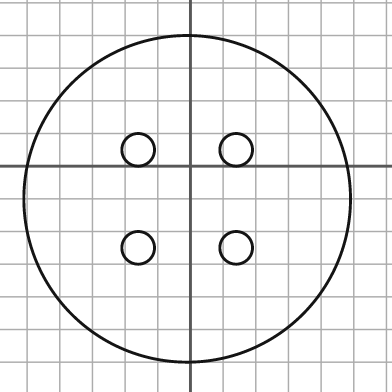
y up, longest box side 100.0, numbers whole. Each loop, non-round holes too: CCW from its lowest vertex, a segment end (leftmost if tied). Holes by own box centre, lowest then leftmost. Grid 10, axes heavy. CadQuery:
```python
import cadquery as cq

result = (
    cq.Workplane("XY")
    .moveTo(-1.0, -10.0)
    .circle(50.0)
    .moveTo(-16.0, -25.0)
    .circle(5.0)
    .moveTo(14.0, -25.0)
    .circle(5.0)
    .moveTo(-16.0, 5.0)
    .circle(5.0)
    .moveTo(14.0, 5.0)
    .circle(5.0)
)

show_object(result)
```